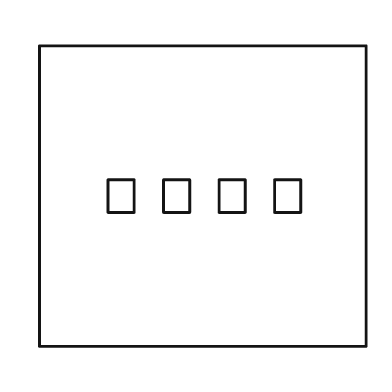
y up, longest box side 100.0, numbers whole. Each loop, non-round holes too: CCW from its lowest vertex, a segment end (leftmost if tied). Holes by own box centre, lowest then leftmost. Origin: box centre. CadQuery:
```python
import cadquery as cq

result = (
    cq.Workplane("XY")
    .moveTo(-50.0, -46.0)
    .lineTo(50.0, -46.0)
    .lineTo(50.0, 46.0)
    .lineTo(-50.0, 46.0)
    .close()
    .moveTo(-29.0, -5.0)
    .lineTo(-21.0, -5.0)
    .lineTo(-21.0, 5.0)
    .lineTo(-29.0, 5.0)
    .close()
    .moveTo(-12.0, -5.0)
    .lineTo(-4.0, -5.0)
    .lineTo(-4.0, 5.0)
    .lineTo(-12.0, 5.0)
    .close()
    .moveTo(5.0, -5.0)
    .lineTo(13.0, -5.0)
    .lineTo(13.0, 5.0)
    .lineTo(5.0, 5.0)
    .close()
    .moveTo(22.0, -5.0)
    .lineTo(30.0, -5.0)
    .lineTo(30.0, 5.0)
    .lineTo(22.0, 5.0)
    .close()
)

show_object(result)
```